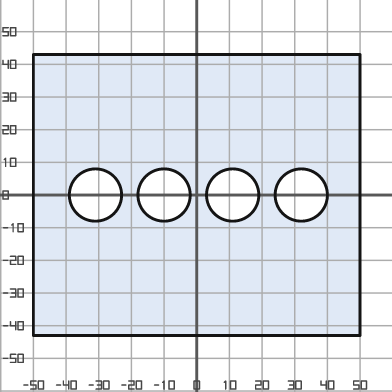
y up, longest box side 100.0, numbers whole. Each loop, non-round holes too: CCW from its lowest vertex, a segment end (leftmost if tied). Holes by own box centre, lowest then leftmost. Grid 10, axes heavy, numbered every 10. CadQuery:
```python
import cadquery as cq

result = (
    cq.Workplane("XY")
    .moveTo(-50.0, -43.0)
    .lineTo(50.0, -43.0)
    .lineTo(50.0, 43.0)
    .lineTo(-50.0, 43.0)
    .close()
    .moveTo(-31.0, 0.0)
    .circle(8.0)
    .moveTo(-10.0, 0.0)
    .circle(8.0)
    .moveTo(11.0, 0.0)
    .circle(8.0)
    .moveTo(32.0, 0.0)
    .circle(8.0)
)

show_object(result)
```